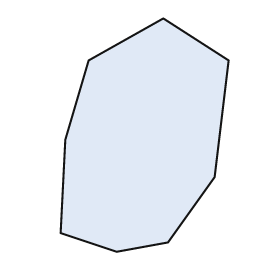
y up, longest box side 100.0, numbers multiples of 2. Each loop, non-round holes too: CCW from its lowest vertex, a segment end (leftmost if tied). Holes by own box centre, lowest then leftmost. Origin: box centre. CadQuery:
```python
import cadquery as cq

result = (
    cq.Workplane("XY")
    .moveTo(-12.0, -50.0)
    .lineTo(10.0, -46.0)
    .lineTo(30.0, -18.0)
    .lineTo(36.0, 32.0)
    .lineTo(8.0, 50.0)
    .lineTo(-24.0, 32.0)
    .lineTo(-34.0, -2.0)
    .lineTo(-36.0, -42.0)
    .close()
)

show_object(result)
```